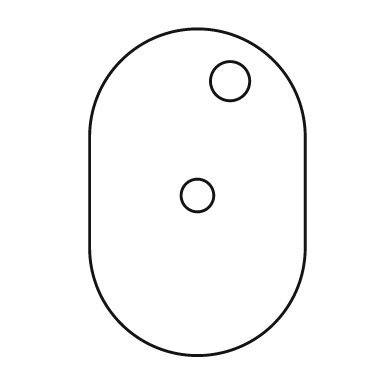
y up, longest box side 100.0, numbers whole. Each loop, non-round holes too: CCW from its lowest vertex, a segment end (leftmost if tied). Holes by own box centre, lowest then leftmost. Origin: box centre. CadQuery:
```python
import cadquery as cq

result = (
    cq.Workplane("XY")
    .moveTo(-33.0, -17.0)
    .threePointArc((0.0, -50.0), (33.0, -17.0))
    .lineTo(33.0, 17.0)
    .threePointArc((0.0, 50.0), (-33.0, 17.0))
    .close()
    .moveTo(0.0, -1.0)
    .circle(5.0)
    .moveTo(10.0, 34.0)
    .circle(6.0)
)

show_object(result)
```